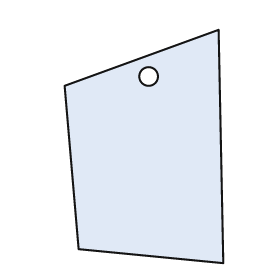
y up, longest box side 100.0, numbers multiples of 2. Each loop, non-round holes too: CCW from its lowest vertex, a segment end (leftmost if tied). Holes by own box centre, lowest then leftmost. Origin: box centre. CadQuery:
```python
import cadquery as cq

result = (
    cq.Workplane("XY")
    .moveTo(34.0, -50.0)
    .lineTo(32.0, 50.0)
    .lineTo(-34.0, 26.0)
    .lineTo(-28.0, -44.0)
    .close()
    .moveTo(2.0, 30.0)
    .circle(4.0)
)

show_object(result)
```